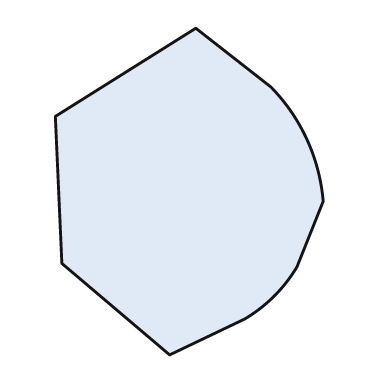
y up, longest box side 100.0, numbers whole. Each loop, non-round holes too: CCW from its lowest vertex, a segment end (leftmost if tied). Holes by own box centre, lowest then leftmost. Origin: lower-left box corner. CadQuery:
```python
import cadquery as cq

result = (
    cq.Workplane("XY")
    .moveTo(35.0, 0.0)
    .lineTo(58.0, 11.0)
    .threePointArc((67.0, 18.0), (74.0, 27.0))
    .lineTo(82.0, 47.0)
    .threePointArc((77.0, 66.0), (66.0, 82.0))
    .lineTo(43.0, 100.0)
    .lineTo(0.0, 73.0)
    .lineTo(2.0, 28.0)
    .close()
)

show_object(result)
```